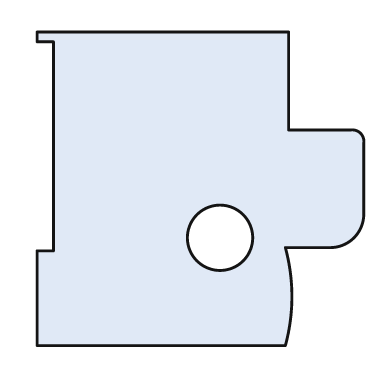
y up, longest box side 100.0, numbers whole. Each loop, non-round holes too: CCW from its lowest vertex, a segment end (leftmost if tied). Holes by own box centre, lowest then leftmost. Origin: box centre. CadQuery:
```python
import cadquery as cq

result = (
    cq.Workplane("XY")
    .moveTo(-50.0, -48.0)
    .lineTo(26.0, -48.0)
    .threePointArc((28.0, -33.0), (26.0, -18.0))
    .lineTo(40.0, -18.0)
    .threePointArc((47.0, -15.0), (50.0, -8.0))
    .lineTo(50.0, 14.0)
    .threePointArc((49.0, 17.0), (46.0, 18.0))
    .lineTo(27.0, 18.0)
    .lineTo(27.0, 48.0)
    .lineTo(-50.0, 48.0)
    .lineTo(-50.0, 45.0)
    .lineTo(-45.0, 45.0)
    .lineTo(-45.0, -19.0)
    .lineTo(-50.0, -19.0)
    .close()
    .moveTo(6.0, -15.0)
    .circle(10.0)
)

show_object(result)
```